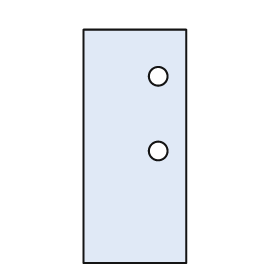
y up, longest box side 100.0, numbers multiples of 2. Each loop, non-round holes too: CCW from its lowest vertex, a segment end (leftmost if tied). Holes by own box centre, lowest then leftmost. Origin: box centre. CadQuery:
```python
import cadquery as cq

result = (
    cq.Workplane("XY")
    .moveTo(-22.0, -50.0)
    .lineTo(22.0, -50.0)
    .lineTo(22.0, 50.0)
    .lineTo(-22.0, 50.0)
    .close()
    .moveTo(10.0, -2.0)
    .circle(4.0)
    .moveTo(10.0, 30.0)
    .circle(4.0)
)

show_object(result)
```